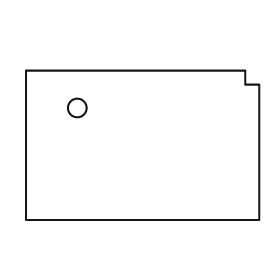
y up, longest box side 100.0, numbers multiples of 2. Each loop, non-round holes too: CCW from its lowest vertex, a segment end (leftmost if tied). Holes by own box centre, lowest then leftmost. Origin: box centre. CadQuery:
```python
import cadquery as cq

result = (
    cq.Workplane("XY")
    .moveTo(-50.0, -32.0)
    .lineTo(50.0, -32.0)
    .lineTo(50.0, 26.0)
    .lineTo(44.0, 26.0)
    .lineTo(44.0, 32.0)
    .lineTo(-50.0, 32.0)
    .close()
    .moveTo(-28.0, 16.0)
    .circle(4.0)
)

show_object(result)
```